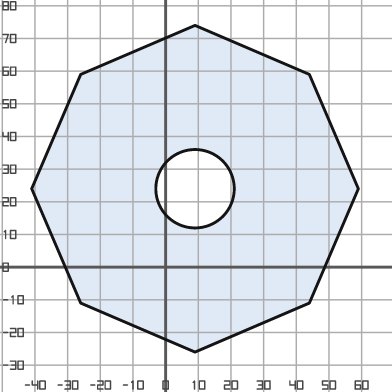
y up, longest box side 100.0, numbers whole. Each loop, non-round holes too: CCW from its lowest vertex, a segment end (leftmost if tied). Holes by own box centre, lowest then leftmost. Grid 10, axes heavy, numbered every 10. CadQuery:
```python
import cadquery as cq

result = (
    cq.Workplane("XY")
    .moveTo(9.0, -26.0)
    .lineTo(44.0, -11.0)
    .lineTo(59.0, 24.0)
    .lineTo(44.0, 59.0)
    .lineTo(9.0, 74.0)
    .lineTo(-26.0, 59.0)
    .lineTo(-41.0, 24.0)
    .lineTo(-26.0, -11.0)
    .close()
    .moveTo(9.0, 24.0)
    .circle(12.0)
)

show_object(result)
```